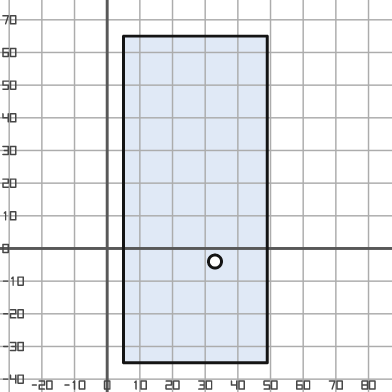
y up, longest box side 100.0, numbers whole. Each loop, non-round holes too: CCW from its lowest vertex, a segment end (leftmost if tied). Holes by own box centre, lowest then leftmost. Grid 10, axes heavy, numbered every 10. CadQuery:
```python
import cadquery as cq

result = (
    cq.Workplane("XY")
    .moveTo(5.0, -35.0)
    .lineTo(49.0, -35.0)
    .lineTo(49.0, 65.0)
    .lineTo(5.0, 65.0)
    .close()
    .moveTo(33.0, -4.0)
    .circle(2.0)
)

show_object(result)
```